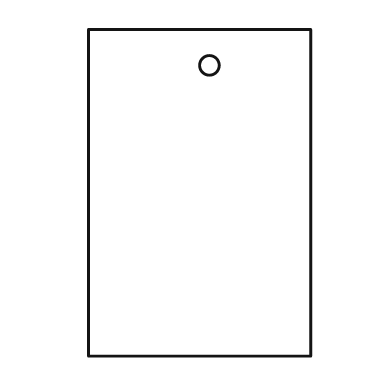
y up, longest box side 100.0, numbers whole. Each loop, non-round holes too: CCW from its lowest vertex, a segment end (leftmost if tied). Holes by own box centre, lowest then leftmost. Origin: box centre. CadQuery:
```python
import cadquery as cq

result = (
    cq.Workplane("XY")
    .moveTo(-34.0, -50.0)
    .lineTo(34.0, -50.0)
    .lineTo(34.0, 50.0)
    .lineTo(-34.0, 50.0)
    .close()
    .moveTo(3.0, 39.0)
    .circle(3.0)
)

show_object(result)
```